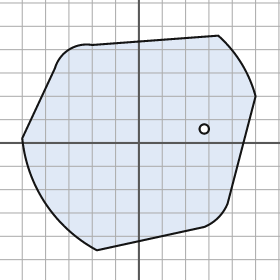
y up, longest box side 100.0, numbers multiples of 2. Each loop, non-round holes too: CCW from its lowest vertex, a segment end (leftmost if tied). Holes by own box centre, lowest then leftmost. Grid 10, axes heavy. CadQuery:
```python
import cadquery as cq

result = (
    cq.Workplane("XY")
    .moveTo(-18.0, -46.0)
    .lineTo(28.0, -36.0)
    .threePointArc((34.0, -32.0), (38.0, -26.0))
    .lineTo(50.0, 20.0)
    .threePointArc((44.0, 34.0), (34.0, 46.0))
    .lineTo(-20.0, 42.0)
    .threePointArc((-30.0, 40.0), (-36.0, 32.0))
    .lineTo(-50.0, 2.0)
    .threePointArc((-40.0, -26.0), (-18.0, -46.0))
    .close()
    .moveTo(28.0, 6.0)
    .circle(2.0)
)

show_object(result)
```